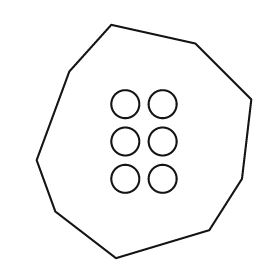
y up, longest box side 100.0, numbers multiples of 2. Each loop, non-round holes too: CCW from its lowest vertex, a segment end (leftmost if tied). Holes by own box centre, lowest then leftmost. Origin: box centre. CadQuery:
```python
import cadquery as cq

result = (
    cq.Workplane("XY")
    .moveTo(-12.0, -50.0)
    .lineTo(28.0, -38.0)
    .lineTo(42.0, -16.0)
    .lineTo(46.0, 18.0)
    .lineTo(22.0, 42.0)
    .lineTo(-14.0, 50.0)
    .lineTo(-32.0, 30.0)
    .lineTo(-46.0, -8.0)
    .lineTo(-38.0, -30.0)
    .close()
    .moveTo(-8.0, -16.0)
    .circle(6.0)
    .moveTo(8.0, -16.0)
    .circle(6.0)
    .moveTo(-8.0, 0.0)
    .circle(6.0)
    .moveTo(8.0, 0.0)
    .circle(6.0)
    .moveTo(-8.0, 16.0)
    .circle(6.0)
    .moveTo(8.0, 16.0)
    .circle(6.0)
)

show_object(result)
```